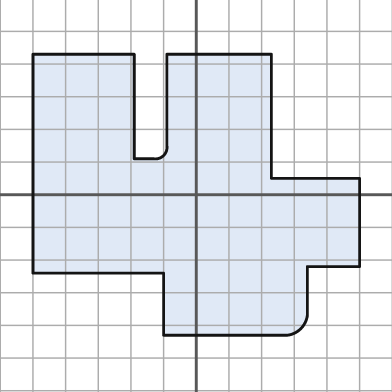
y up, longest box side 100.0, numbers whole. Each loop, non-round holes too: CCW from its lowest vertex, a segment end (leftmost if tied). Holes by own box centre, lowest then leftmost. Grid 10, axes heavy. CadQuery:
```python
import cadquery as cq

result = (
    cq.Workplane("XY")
    .moveTo(-10.0, -43.0)
    .lineTo(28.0, -43.0)
    .threePointArc((32.0, -41.0), (34.0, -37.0))
    .lineTo(34.0, -22.0)
    .lineTo(50.0, -22.0)
    .lineTo(50.0, 5.0)
    .lineTo(23.0, 5.0)
    .lineTo(23.0, 43.0)
    .lineTo(-9.0, 43.0)
    .lineTo(-9.0, 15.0)
    .threePointArc((-10.0, 12.0), (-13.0, 11.0))
    .lineTo(-19.0, 11.0)
    .lineTo(-19.0, 43.0)
    .lineTo(-50.0, 43.0)
    .lineTo(-50.0, -24.0)
    .lineTo(-10.0, -24.0)
    .close()
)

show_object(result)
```